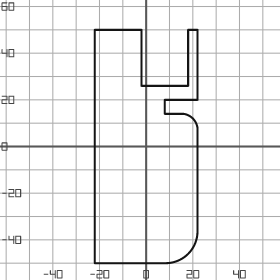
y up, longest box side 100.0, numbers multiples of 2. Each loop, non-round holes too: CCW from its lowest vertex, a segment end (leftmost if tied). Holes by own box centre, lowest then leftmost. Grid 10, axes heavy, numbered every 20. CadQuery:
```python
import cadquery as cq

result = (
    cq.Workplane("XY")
    .moveTo(-22.0, -50.0)
    .lineTo(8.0, -50.0)
    .threePointArc((18.0, -46.0), (22.0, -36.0))
    .lineTo(22.0, 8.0)
    .threePointArc((20.0, 12.0), (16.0, 14.0))
    .lineTo(8.0, 14.0)
    .lineTo(8.0, 20.0)
    .lineTo(22.0, 20.0)
    .lineTo(22.0, 50.0)
    .lineTo(18.0, 50.0)
    .lineTo(18.0, 26.0)
    .lineTo(-2.0, 26.0)
    .lineTo(-2.0, 50.0)
    .lineTo(-22.0, 50.0)
    .close()
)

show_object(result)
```